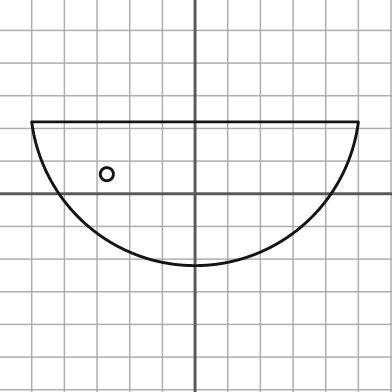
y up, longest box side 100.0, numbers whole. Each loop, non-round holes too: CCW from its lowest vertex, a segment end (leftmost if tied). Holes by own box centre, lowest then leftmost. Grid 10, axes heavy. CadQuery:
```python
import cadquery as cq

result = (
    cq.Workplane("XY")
    .moveTo(-50.0, 22.0)
    .threePointArc((0.0, -22.0), (50.0, 22.0))
    .close()
    .moveTo(-27.0, 6.0)
    .circle(2.0)
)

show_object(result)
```